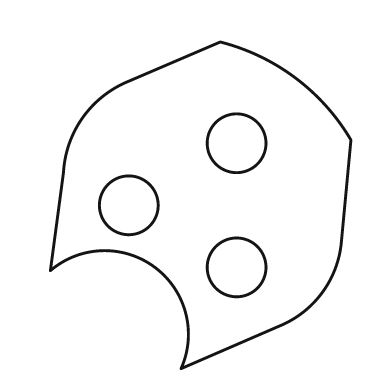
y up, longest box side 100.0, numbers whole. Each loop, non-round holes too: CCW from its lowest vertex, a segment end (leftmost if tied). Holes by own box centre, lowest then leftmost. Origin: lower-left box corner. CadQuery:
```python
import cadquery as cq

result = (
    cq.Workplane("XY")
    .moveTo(40.0, 0.0)
    .lineTo(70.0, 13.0)
    .threePointArc((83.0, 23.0), (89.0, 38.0))
    .lineTo(92.0, 70.0)
    .threePointArc((75.0, 89.0), (52.0, 100.0))
    .lineTo(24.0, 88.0)
    .threePointArc((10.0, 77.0), (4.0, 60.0))
    .lineTo(0.0, 30.0)
    .threePointArc((32.0, 31.0), (40.0, 0.0))
    .close()
    .moveTo(57.0, 31.0)
    .circle(9.0)
    .moveTo(24.0, 50.0)
    .circle(9.0)
    .moveTo(57.0, 69.0)
    .circle(9.0)
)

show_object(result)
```